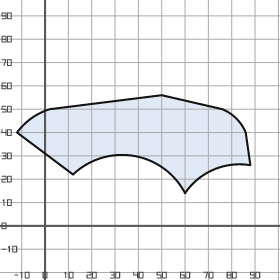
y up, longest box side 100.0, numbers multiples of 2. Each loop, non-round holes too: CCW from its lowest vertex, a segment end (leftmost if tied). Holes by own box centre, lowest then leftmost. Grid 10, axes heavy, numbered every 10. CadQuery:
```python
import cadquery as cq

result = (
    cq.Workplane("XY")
    .moveTo(60.0, 14.0)
    .threePointArc((72.0, 24.0), (88.0, 26.0))
    .lineTo(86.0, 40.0)
    .threePointArc((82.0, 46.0), (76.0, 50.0))
    .lineTo(50.0, 56.0)
    .lineTo(2.0, 50.0)
    .threePointArc((-6.0, 46.0), (-12.0, 40.0))
    .lineTo(12.0, 22.0)
    .threePointArc((38.0, 30.0), (60.0, 14.0))
    .close()
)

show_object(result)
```